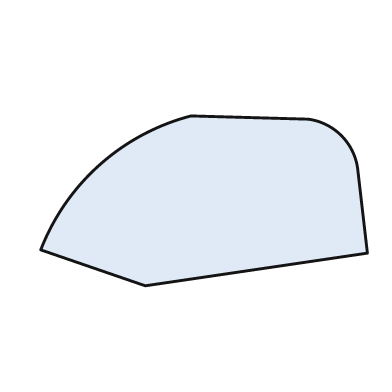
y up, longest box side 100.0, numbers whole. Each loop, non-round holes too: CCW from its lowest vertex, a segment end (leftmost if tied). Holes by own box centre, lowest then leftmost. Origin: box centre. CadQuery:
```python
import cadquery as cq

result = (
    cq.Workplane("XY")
    .moveTo(-18.0, -26.0)
    .lineTo(50.0, -16.0)
    .lineTo(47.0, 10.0)
    .threePointArc((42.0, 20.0), (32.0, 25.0))
    .lineTo(-4.0, 26.0)
    .threePointArc((-32.0, 11.0), (-50.0, -15.0))
    .close()
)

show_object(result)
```